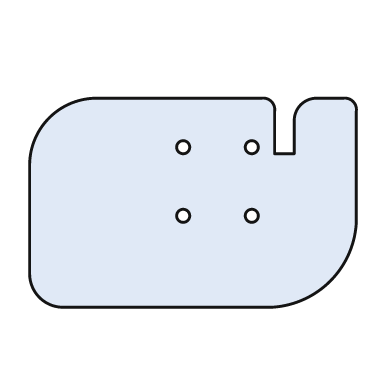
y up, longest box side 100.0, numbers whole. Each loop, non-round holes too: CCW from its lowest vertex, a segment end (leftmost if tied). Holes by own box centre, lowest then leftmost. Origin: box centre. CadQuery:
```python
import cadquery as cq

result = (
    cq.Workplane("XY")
    .moveTo(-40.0, -32.0)
    .lineTo(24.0, -32.0)
    .threePointArc((42.0, -24.0), (50.0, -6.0))
    .lineTo(50.0, 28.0)
    .threePointArc((49.0, 31.0), (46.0, 32.0))
    .lineTo(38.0, 32.0)
    .threePointArc((33.0, 30.0), (31.0, 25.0))
    .lineTo(31.0, 15.0)
    .lineTo(25.0, 15.0)
    .lineTo(25.0, 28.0)
    .threePointArc((24.0, 31.0), (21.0, 32.0))
    .lineTo(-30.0, 32.0)
    .threePointArc((-44.0, 26.0), (-50.0, 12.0))
    .lineTo(-50.0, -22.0)
    .threePointArc((-47.0, -29.0), (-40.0, -32.0))
    .close()
    .moveTo(-3.0, -4.0)
    .circle(2.0)
    .moveTo(18.0, -4.0)
    .circle(2.0)
    .moveTo(-3.0, 17.0)
    .circle(2.0)
    .moveTo(18.0, 17.0)
    .circle(2.0)
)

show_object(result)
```